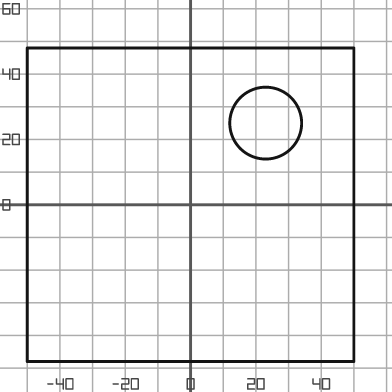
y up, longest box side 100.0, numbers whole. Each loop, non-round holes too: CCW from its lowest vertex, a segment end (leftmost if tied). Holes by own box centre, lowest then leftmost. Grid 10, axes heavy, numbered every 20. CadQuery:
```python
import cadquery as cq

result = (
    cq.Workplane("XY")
    .moveTo(-50.0, -48.0)
    .lineTo(50.0, -48.0)
    .lineTo(50.0, 48.0)
    .lineTo(-50.0, 48.0)
    .close()
    .moveTo(23.0, 25.0)
    .circle(11.0)
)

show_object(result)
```